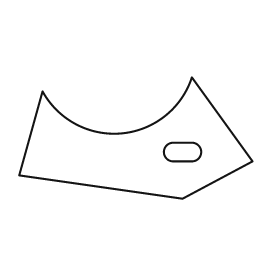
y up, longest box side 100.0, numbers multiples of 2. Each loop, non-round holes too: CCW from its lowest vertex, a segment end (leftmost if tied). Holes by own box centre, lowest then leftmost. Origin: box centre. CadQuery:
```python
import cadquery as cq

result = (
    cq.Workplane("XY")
    .moveTo(20.0, -26.0)
    .lineTo(50.0, -10.0)
    .lineTo(24.0, 26.0)
    .threePointArc((-6.0, 2.0), (-40.0, 20.0))
    .lineTo(-50.0, -16.0)
    .close()
    .moveTo(16.0, -10.0)
    .lineTo(24.0, -10.0)
    .threePointArc((28.0, -6.0), (24.0, -2.0))
    .lineTo(16.0, -2.0)
    .threePointArc((12.0, -6.0), (16.0, -10.0))
    .close()
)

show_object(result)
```